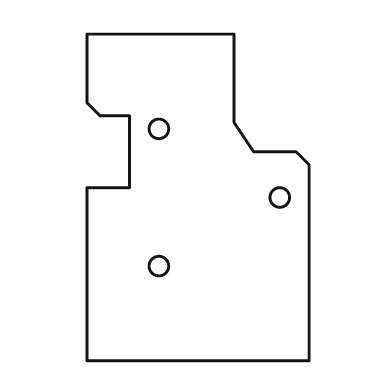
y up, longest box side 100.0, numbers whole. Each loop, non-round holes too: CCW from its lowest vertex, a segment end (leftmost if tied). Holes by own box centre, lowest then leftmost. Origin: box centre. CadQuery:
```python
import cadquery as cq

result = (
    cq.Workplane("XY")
    .moveTo(-34.0, -50.0)
    .lineTo(34.0, -50.0)
    .lineTo(34.0, 10.0)
    .lineTo(30.0, 14.0)
    .lineTo(17.0, 14.0)
    .lineTo(11.0, 23.0)
    .lineTo(11.0, 50.0)
    .lineTo(-34.0, 50.0)
    .lineTo(-34.0, 29.0)
    .lineTo(-30.0, 25.0)
    .lineTo(-21.0, 25.0)
    .lineTo(-21.0, 3.0)
    .lineTo(-34.0, 3.0)
    .close()
    .moveTo(-12.0, -21.0)
    .circle(3.0)
    .moveTo(25.0, 0.0)
    .circle(3.0)
    .moveTo(-12.0, 21.0)
    .circle(3.0)
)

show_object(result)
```